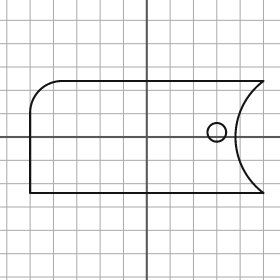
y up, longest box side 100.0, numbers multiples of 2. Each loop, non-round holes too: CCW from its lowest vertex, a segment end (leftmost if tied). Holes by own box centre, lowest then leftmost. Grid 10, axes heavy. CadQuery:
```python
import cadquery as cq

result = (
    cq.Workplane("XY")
    .moveTo(-50.0, -24.0)
    .lineTo(50.0, -24.0)
    .threePointArc((38.0, 0.0), (50.0, 24.0))
    .lineTo(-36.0, 24.0)
    .threePointArc((-46.0, 20.0), (-50.0, 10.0))
    .close()
    .moveTo(30.0, 2.0)
    .circle(4.0)
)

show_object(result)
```